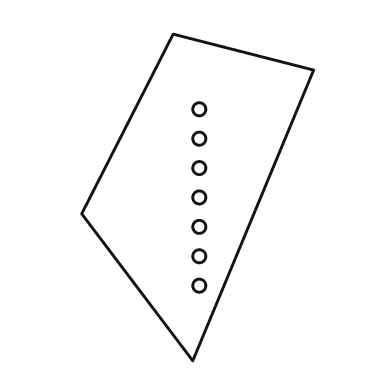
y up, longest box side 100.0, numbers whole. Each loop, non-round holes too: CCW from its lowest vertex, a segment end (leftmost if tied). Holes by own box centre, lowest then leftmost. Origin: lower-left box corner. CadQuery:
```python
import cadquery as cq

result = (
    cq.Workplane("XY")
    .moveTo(34.0, 0.0)
    .lineTo(71.0, 89.0)
    .lineTo(28.0, 100.0)
    .lineTo(0.0, 45.0)
    .close()
    .moveTo(36.0, 23.0)
    .circle(2.0)
    .moveTo(36.0, 32.0)
    .circle(2.0)
    .moveTo(36.0, 41.0)
    .circle(2.0)
    .moveTo(36.0, 50.0)
    .circle(2.0)
    .moveTo(36.0, 59.0)
    .circle(2.0)
    .moveTo(36.0, 68.0)
    .circle(2.0)
    .moveTo(36.0, 77.0)
    .circle(2.0)
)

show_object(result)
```